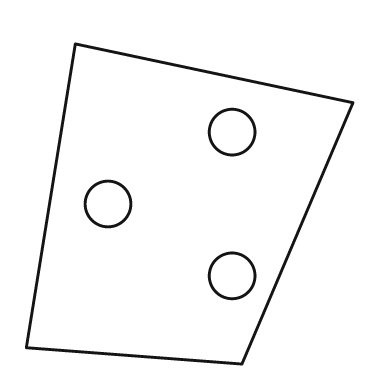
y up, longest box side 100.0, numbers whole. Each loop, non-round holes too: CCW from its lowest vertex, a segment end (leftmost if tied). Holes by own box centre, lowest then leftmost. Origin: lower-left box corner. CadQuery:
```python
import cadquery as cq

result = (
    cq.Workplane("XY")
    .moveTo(66.0, 0.0)
    .lineTo(100.0, 80.0)
    .lineTo(15.0, 98.0)
    .lineTo(0.0, 5.0)
    .close()
    .moveTo(63.0, 27.0)
    .circle(7.0)
    .moveTo(25.0, 49.0)
    .circle(7.0)
    .moveTo(63.0, 71.0)
    .circle(7.0)
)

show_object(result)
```